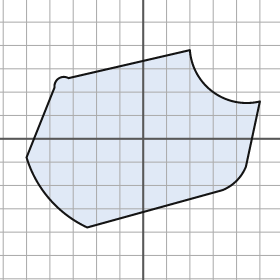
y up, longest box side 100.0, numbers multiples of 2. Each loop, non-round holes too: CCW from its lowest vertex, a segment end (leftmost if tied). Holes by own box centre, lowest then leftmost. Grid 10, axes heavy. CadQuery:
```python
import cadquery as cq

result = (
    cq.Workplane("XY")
    .moveTo(-24.0, -38.0)
    .lineTo(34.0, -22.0)
    .threePointArc((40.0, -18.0), (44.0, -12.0))
    .lineTo(50.0, 16.0)
    .threePointArc((30.0, 20.0), (20.0, 38.0))
    .lineTo(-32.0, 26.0)
    .threePointArc((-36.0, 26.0), (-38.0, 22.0))
    .lineTo(-50.0, -8.0)
    .threePointArc((-40.0, -26.0), (-24.0, -38.0))
    .close()
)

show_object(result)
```